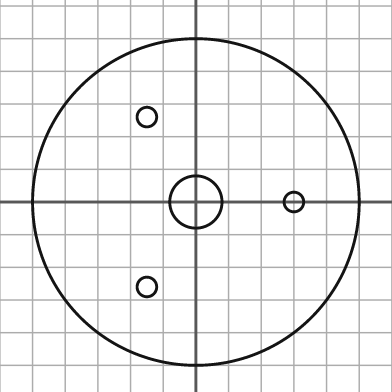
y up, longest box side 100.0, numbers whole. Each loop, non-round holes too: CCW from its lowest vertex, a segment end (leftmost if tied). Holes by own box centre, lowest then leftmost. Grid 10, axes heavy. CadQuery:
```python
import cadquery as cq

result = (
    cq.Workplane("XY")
    .moveTo(0.0, 0.0)
    .circle(50.0)
    .moveTo(-15.0, -26.0)
    .circle(3.0)
    .moveTo(0.0, 0.0)
    .circle(8.0)
    .moveTo(30.0, 0.0)
    .circle(3.0)
    .moveTo(-15.0, 26.0)
    .circle(3.0)
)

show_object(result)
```